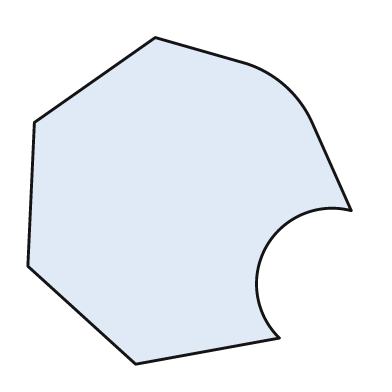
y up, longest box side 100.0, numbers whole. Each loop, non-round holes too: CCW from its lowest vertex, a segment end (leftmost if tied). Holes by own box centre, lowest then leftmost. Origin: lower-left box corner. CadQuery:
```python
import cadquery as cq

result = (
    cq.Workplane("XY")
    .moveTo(33.0, 0.0)
    .lineTo(77.0, 8.0)
    .threePointArc((73.0, 36.0), (99.0, 47.0))
    .lineTo(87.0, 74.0)
    .threePointArc((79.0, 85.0), (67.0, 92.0))
    .lineTo(39.0, 100.0)
    .lineTo(2.0, 74.0)
    .lineTo(0.0, 30.0)
    .close()
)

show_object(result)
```